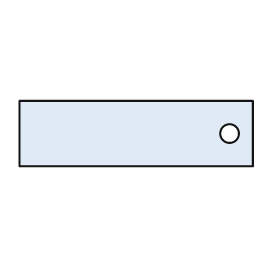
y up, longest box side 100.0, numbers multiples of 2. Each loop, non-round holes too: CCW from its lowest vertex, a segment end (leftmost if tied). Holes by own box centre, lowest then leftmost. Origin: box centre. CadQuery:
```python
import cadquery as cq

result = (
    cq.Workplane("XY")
    .moveTo(-50.0, -14.0)
    .lineTo(50.0, -14.0)
    .lineTo(50.0, 14.0)
    .lineTo(-50.0, 14.0)
    .close()
    .moveTo(40.0, 0.0)
    .circle(4.0)
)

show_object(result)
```